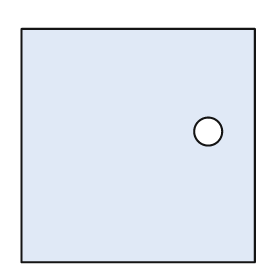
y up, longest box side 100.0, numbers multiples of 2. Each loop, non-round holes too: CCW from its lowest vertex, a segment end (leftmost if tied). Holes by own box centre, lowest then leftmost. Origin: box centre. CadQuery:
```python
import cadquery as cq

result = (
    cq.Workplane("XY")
    .moveTo(-50.0, -50.0)
    .lineTo(50.0, -50.0)
    .lineTo(50.0, 50.0)
    .lineTo(-50.0, 50.0)
    .close()
    .moveTo(30.0, 6.0)
    .circle(6.0)
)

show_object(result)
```